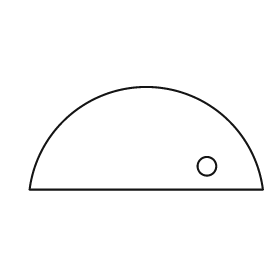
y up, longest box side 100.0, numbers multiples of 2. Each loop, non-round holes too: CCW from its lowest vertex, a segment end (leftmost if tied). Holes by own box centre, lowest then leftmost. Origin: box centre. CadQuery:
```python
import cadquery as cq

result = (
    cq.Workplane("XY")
    .moveTo(-50.0, -22.0)
    .lineTo(50.0, -22.0)
    .threePointArc((0.0, 22.0), (-50.0, -22.0))
    .close()
    .moveTo(26.0, -12.0)
    .circle(4.0)
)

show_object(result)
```